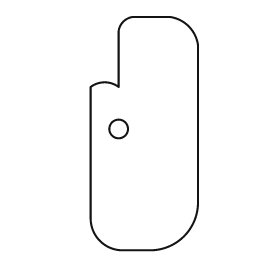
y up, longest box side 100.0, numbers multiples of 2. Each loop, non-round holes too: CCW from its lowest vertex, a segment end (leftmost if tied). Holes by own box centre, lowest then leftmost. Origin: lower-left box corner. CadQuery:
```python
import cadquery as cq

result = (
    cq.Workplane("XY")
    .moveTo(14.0, 0.0)
    .lineTo(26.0, 0.0)
    .threePointArc((40.0, 6.0), (46.0, 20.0))
    .lineTo(46.0, 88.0)
    .threePointArc((42.0, 96.0), (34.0, 100.0))
    .lineTo(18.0, 100.0)
    .threePointArc((14.0, 98.0), (12.0, 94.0))
    .lineTo(12.0, 70.0)
    .threePointArc((6.0, 72.0), (0.0, 70.0))
    .lineTo(0.0, 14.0)
    .threePointArc((4.0, 4.0), (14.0, 0.0))
    .close()
    .moveTo(12.0, 52.0)
    .circle(4.0)
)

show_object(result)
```